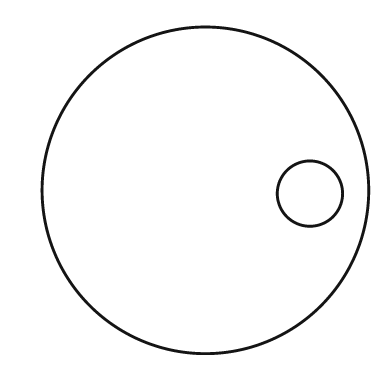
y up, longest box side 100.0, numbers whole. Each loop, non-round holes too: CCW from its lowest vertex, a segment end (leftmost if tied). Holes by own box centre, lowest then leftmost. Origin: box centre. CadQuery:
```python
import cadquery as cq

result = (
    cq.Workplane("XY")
    .moveTo(0.0, 0.0)
    .circle(50.0)
    .moveTo(32.0, -1.0)
    .circle(10.0)
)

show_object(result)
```